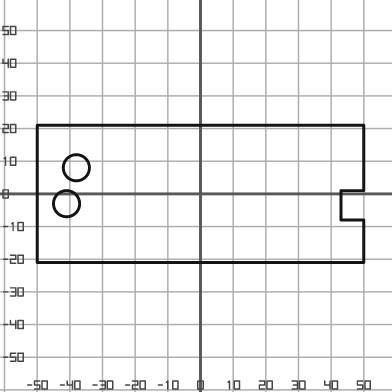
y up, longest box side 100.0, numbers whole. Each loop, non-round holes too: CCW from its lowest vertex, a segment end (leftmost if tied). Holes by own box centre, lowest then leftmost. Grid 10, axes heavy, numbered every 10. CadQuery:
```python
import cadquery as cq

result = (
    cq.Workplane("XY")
    .moveTo(-50.0, -21.0)
    .lineTo(50.0, -21.0)
    .lineTo(50.0, -8.0)
    .lineTo(43.0, -8.0)
    .lineTo(43.0, 1.0)
    .lineTo(50.0, 1.0)
    .lineTo(50.0, 21.0)
    .lineTo(-50.0, 21.0)
    .close()
    .moveTo(-41.0, -3.0)
    .circle(4.0)
    .moveTo(-38.0, 8.0)
    .circle(4.0)
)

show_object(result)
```